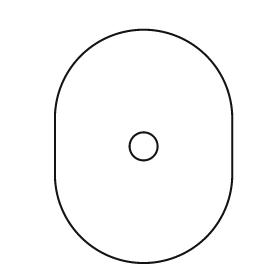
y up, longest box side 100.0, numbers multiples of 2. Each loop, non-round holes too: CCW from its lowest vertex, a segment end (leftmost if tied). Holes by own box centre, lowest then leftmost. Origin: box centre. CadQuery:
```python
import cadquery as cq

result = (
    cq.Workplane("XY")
    .moveTo(-38.0, -12.0)
    .threePointArc((0.0, -50.0), (38.0, -12.0))
    .lineTo(38.0, 12.0)
    .threePointArc((0.0, 50.0), (-38.0, 12.0))
    .close()
    .moveTo(0.0, 0.0)
    .circle(6.0)
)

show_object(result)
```